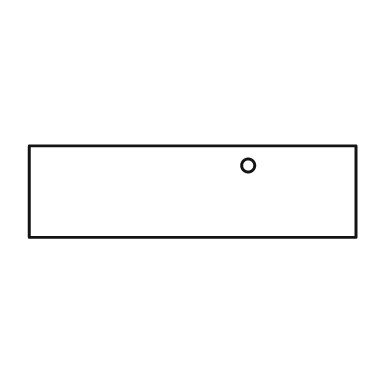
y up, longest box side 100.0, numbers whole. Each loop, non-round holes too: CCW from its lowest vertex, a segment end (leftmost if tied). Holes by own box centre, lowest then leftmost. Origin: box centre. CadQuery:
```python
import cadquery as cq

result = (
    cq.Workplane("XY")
    .moveTo(-50.0, -14.0)
    .lineTo(50.0, -14.0)
    .lineTo(50.0, 14.0)
    .lineTo(-50.0, 14.0)
    .close()
    .moveTo(17.0, 8.0)
    .circle(2.0)
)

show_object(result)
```